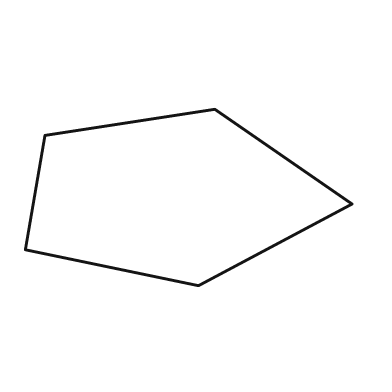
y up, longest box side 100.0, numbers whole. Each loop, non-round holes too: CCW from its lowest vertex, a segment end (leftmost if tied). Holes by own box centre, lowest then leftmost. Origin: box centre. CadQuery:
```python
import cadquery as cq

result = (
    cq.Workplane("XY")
    .moveTo(3.0, -27.0)
    .lineTo(50.0, -2.0)
    .lineTo(8.0, 27.0)
    .lineTo(-44.0, 19.0)
    .lineTo(-50.0, -16.0)
    .close()
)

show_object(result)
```